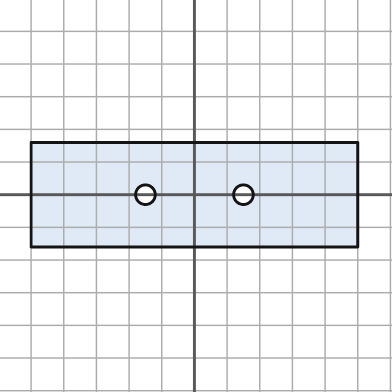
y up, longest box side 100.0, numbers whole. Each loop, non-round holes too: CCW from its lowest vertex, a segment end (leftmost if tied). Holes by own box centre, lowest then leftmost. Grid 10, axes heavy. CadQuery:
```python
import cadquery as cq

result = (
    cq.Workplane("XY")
    .moveTo(-50.0, -16.0)
    .lineTo(50.0, -16.0)
    .lineTo(50.0, 16.0)
    .lineTo(-50.0, 16.0)
    .close()
    .moveTo(-15.0, 0.0)
    .circle(3.0)
    .moveTo(15.0, 0.0)
    .circle(3.0)
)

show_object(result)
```